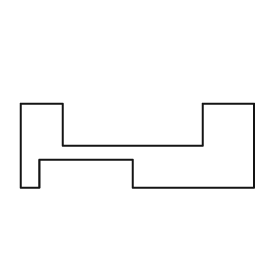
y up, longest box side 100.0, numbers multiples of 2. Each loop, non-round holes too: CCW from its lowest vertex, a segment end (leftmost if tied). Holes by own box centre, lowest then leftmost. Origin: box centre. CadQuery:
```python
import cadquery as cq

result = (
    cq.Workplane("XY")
    .moveTo(-50.0, -18.0)
    .lineTo(-42.0, -18.0)
    .lineTo(-42.0, -6.0)
    .lineTo(-2.0, -6.0)
    .lineTo(-2.0, -18.0)
    .lineTo(50.0, -18.0)
    .lineTo(50.0, 18.0)
    .lineTo(28.0, 18.0)
    .lineTo(28.0, 0.0)
    .lineTo(-32.0, 0.0)
    .lineTo(-32.0, 18.0)
    .lineTo(-50.0, 18.0)
    .close()
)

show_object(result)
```